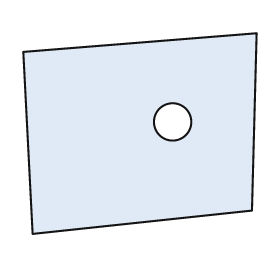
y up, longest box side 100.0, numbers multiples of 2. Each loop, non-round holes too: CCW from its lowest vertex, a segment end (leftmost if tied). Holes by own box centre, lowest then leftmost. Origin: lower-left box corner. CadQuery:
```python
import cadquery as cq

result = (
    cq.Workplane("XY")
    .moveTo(4.0, 0.0)
    .lineTo(98.0, 10.0)
    .lineTo(100.0, 86.0)
    .lineTo(0.0, 78.0)
    .close()
    .moveTo(64.0, 48.0)
    .circle(8.0)
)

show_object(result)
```